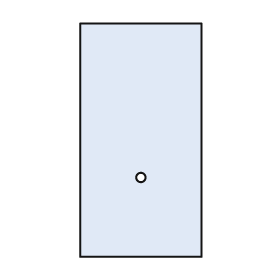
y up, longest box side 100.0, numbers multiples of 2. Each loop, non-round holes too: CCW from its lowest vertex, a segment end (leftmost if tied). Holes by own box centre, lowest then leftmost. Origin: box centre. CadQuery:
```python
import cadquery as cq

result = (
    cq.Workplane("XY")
    .moveTo(-26.0, -50.0)
    .lineTo(26.0, -50.0)
    .lineTo(26.0, 50.0)
    .lineTo(-26.0, 50.0)
    .close()
    .moveTo(0.0, -16.0)
    .circle(2.0)
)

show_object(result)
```